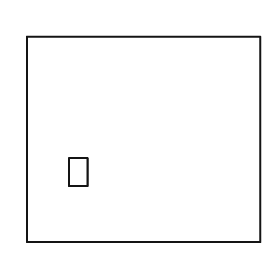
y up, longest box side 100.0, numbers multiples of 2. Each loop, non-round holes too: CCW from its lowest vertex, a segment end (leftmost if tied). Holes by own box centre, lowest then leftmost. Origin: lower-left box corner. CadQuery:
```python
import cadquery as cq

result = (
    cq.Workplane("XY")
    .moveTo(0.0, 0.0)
    .lineTo(100.0, 0.0)
    .lineTo(100.0, 88.0)
    .lineTo(0.0, 88.0)
    .close()
    .moveTo(18.0, 24.0)
    .lineTo(26.0, 24.0)
    .lineTo(26.0, 36.0)
    .lineTo(18.0, 36.0)
    .close()
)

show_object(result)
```